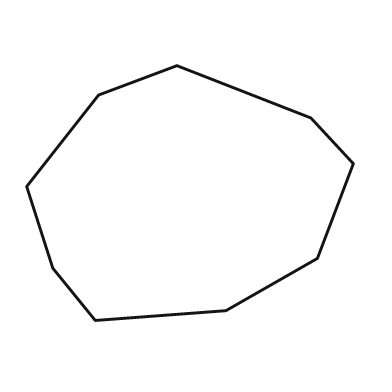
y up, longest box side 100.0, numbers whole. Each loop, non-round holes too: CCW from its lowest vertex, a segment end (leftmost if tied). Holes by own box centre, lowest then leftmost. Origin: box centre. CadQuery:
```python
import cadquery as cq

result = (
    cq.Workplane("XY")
    .moveTo(-29.0, -39.0)
    .lineTo(11.0, -36.0)
    .lineTo(39.0, -20.0)
    .lineTo(50.0, 9.0)
    .lineTo(37.0, 23.0)
    .lineTo(-4.0, 39.0)
    .lineTo(-28.0, 30.0)
    .lineTo(-50.0, 2.0)
    .lineTo(-42.0, -23.0)
    .close()
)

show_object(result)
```